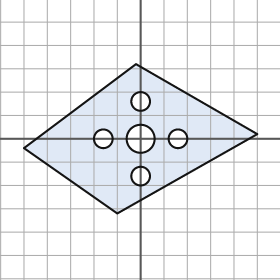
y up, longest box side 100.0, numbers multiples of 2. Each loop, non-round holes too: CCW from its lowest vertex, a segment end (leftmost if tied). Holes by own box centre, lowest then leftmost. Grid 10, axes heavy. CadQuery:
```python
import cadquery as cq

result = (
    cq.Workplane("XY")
    .moveTo(-10.0, -32.0)
    .lineTo(50.0, 2.0)
    .lineTo(-2.0, 32.0)
    .lineTo(-50.0, -4.0)
    .close()
    .moveTo(0.0, -16.0)
    .circle(4.0)
    .moveTo(-16.0, 0.0)
    .circle(4.0)
    .moveTo(0.0, 0.0)
    .circle(6.0)
    .moveTo(16.0, 0.0)
    .circle(4.0)
    .moveTo(0.0, 16.0)
    .circle(4.0)
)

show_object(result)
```